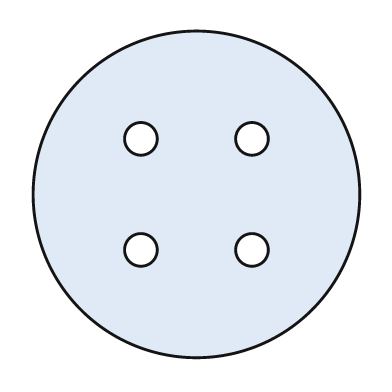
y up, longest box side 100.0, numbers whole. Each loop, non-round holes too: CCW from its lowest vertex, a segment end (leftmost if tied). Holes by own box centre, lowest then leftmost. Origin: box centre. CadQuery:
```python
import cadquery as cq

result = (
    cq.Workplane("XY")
    .moveTo(0.0, 0.0)
    .circle(50.0)
    .moveTo(-17.0, -17.0)
    .circle(5.0)
    .moveTo(17.0, -17.0)
    .circle(5.0)
    .moveTo(-17.0, 17.0)
    .circle(5.0)
    .moveTo(17.0, 17.0)
    .circle(5.0)
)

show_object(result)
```